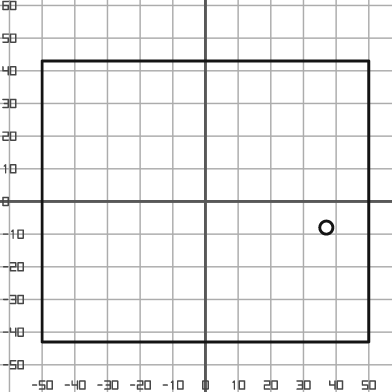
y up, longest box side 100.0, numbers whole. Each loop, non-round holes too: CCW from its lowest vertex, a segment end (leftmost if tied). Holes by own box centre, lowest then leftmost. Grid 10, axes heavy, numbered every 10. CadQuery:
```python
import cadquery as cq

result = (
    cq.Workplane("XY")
    .moveTo(-50.0, -43.0)
    .lineTo(50.0, -43.0)
    .lineTo(50.0, 43.0)
    .lineTo(-50.0, 43.0)
    .close()
    .moveTo(37.0, -8.0)
    .circle(2.0)
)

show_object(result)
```